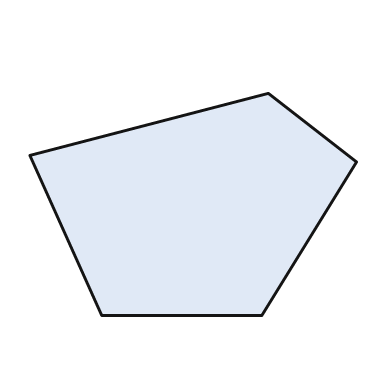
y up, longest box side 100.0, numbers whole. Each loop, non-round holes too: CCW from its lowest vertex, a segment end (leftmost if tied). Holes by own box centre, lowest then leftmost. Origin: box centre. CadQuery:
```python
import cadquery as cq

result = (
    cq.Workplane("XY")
    .moveTo(-28.0, -34.0)
    .lineTo(21.0, -34.0)
    .lineTo(50.0, 13.0)
    .lineTo(23.0, 34.0)
    .lineTo(-50.0, 15.0)
    .close()
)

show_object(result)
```